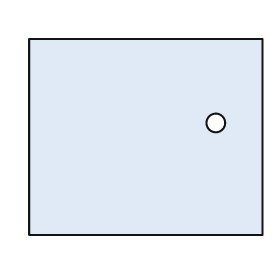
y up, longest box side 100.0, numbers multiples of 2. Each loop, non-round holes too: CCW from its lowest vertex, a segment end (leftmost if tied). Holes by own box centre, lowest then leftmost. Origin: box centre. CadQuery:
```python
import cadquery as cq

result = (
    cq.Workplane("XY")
    .moveTo(-50.0, -42.0)
    .lineTo(50.0, -42.0)
    .lineTo(50.0, 42.0)
    .lineTo(-50.0, 42.0)
    .close()
    .moveTo(30.0, 6.0)
    .circle(4.0)
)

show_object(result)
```